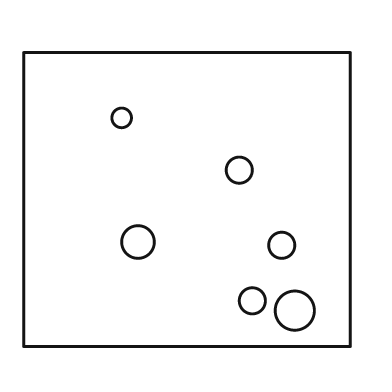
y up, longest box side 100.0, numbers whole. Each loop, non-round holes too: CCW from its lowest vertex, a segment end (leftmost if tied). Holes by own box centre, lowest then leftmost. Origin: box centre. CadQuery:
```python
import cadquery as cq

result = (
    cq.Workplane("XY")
    .moveTo(-50.0, -45.0)
    .lineTo(50.0, -45.0)
    .lineTo(50.0, 45.0)
    .lineTo(-50.0, 45.0)
    .close()
    .moveTo(33.0, -34.0)
    .circle(6.0)
    .moveTo(20.0, -31.0)
    .circle(4.0)
    .moveTo(29.0, -14.0)
    .circle(4.0)
    .moveTo(-15.0, -13.0)
    .circle(5.0)
    .moveTo(16.0, 9.0)
    .circle(4.0)
    .moveTo(-20.0, 25.0)
    .circle(3.0)
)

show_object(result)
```